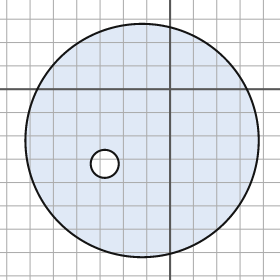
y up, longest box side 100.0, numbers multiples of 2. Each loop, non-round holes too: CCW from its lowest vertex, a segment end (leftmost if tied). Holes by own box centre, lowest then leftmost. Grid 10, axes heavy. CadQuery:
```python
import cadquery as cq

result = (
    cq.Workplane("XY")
    .moveTo(-12.0, -22.0)
    .circle(50.0)
    .moveTo(-28.0, -32.0)
    .circle(6.0)
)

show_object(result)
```